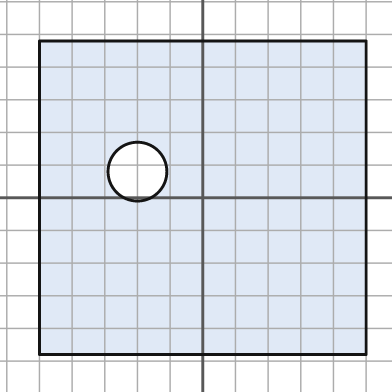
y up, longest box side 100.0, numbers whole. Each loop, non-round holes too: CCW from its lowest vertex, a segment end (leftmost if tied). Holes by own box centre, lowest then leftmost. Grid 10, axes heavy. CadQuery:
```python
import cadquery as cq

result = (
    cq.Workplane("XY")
    .moveTo(-50.0, -48.0)
    .lineTo(50.0, -48.0)
    .lineTo(50.0, 48.0)
    .lineTo(-50.0, 48.0)
    .close()
    .moveTo(-20.0, 8.0)
    .circle(9.0)
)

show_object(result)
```